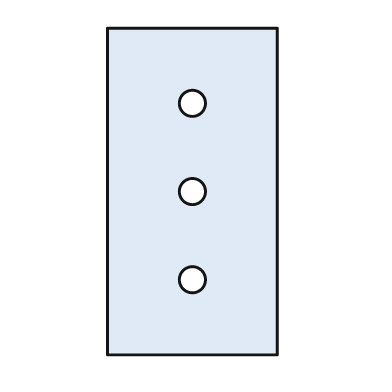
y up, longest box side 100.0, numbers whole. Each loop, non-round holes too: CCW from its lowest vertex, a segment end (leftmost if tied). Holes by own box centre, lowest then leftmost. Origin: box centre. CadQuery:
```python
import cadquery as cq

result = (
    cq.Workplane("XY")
    .moveTo(-26.0, -50.0)
    .lineTo(26.0, -50.0)
    .lineTo(26.0, 50.0)
    .lineTo(-26.0, 50.0)
    .close()
    .moveTo(0.0, -27.0)
    .circle(4.0)
    .moveTo(0.0, 0.0)
    .circle(4.0)
    .moveTo(0.0, 27.0)
    .circle(4.0)
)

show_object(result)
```